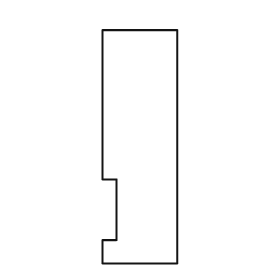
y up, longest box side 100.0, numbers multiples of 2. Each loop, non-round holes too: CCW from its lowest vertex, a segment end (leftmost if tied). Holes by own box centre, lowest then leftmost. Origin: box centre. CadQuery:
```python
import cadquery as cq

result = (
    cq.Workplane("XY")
    .moveTo(-16.0, -50.0)
    .lineTo(16.0, -50.0)
    .lineTo(16.0, 50.0)
    .lineTo(-16.0, 50.0)
    .lineTo(-16.0, -14.0)
    .lineTo(-10.0, -14.0)
    .lineTo(-10.0, -40.0)
    .lineTo(-16.0, -40.0)
    .close()
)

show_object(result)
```